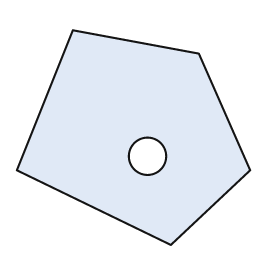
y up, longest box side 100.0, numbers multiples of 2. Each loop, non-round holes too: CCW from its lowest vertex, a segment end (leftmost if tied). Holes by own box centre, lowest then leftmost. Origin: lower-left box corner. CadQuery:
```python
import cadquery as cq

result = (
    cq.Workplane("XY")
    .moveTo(66.0, 0.0)
    .lineTo(100.0, 32.0)
    .lineTo(78.0, 82.0)
    .lineTo(24.0, 92.0)
    .lineTo(0.0, 32.0)
    .close()
    .moveTo(56.0, 38.0)
    .circle(8.0)
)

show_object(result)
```